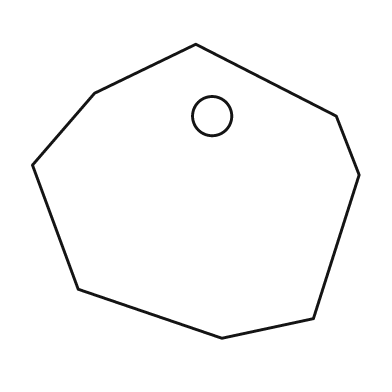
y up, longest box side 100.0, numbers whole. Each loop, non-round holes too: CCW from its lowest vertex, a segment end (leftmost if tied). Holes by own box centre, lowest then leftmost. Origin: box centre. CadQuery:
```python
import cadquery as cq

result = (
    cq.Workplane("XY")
    .moveTo(8.0, -45.0)
    .lineTo(36.0, -39.0)
    .lineTo(50.0, 5.0)
    .lineTo(43.0, 23.0)
    .lineTo(0.0, 45.0)
    .lineTo(-31.0, 30.0)
    .lineTo(-50.0, 8.0)
    .lineTo(-36.0, -30.0)
    .close()
    .moveTo(5.0, 23.0)
    .circle(6.0)
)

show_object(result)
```